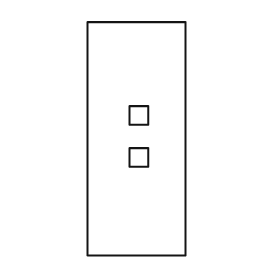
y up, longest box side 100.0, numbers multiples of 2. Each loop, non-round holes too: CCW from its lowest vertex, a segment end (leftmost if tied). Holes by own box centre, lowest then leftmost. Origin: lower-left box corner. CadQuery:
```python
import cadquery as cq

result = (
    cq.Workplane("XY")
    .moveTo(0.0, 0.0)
    .lineTo(42.0, 0.0)
    .lineTo(42.0, 100.0)
    .lineTo(0.0, 100.0)
    .close()
    .moveTo(18.0, 38.0)
    .lineTo(26.0, 38.0)
    .lineTo(26.0, 46.0)
    .lineTo(18.0, 46.0)
    .close()
    .moveTo(18.0, 56.0)
    .lineTo(26.0, 56.0)
    .lineTo(26.0, 64.0)
    .lineTo(18.0, 64.0)
    .close()
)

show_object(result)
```